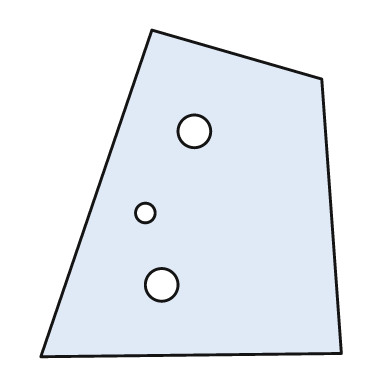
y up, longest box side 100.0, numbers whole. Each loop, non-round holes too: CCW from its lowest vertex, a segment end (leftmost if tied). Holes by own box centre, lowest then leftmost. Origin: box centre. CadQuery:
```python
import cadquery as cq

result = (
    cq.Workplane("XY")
    .moveTo(-46.0, -50.0)
    .lineTo(46.0, -49.0)
    .lineTo(40.0, 35.0)
    .lineTo(-12.0, 50.0)
    .close()
    .moveTo(-9.0, -28.0)
    .circle(5.0)
    .moveTo(-14.0, -6.0)
    .circle(3.0)
    .moveTo(1.0, 19.0)
    .circle(5.0)
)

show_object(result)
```